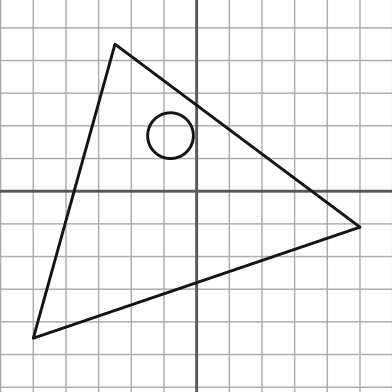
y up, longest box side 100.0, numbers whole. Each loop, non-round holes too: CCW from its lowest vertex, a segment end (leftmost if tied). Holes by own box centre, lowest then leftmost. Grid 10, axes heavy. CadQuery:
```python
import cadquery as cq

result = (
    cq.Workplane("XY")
    .moveTo(-50.0, -45.0)
    .lineTo(50.0, -11.0)
    .lineTo(-25.0, 45.0)
    .close()
    .moveTo(-8.0, 17.0)
    .circle(7.0)
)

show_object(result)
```